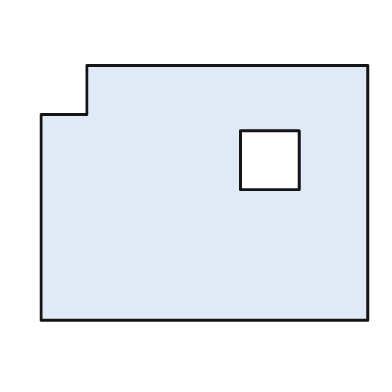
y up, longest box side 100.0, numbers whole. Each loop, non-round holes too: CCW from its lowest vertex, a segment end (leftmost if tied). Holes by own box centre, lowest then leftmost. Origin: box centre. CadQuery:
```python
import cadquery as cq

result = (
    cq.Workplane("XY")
    .moveTo(-50.0, -39.0)
    .lineTo(50.0, -39.0)
    .lineTo(50.0, 39.0)
    .lineTo(-36.0, 39.0)
    .lineTo(-36.0, 24.0)
    .lineTo(-50.0, 24.0)
    .close()
    .moveTo(11.0, 1.0)
    .lineTo(29.0, 1.0)
    .lineTo(29.0, 19.0)
    .lineTo(11.0, 19.0)
    .close()
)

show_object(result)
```